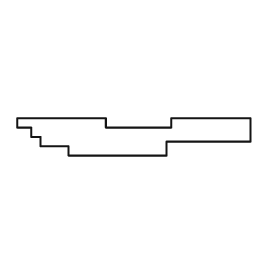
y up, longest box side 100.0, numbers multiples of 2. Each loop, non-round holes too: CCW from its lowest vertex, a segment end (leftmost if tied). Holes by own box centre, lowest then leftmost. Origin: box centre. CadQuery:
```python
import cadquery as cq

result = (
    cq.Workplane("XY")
    .moveTo(-28.0, -8.0)
    .lineTo(14.0, -8.0)
    .lineTo(14.0, -2.0)
    .lineTo(50.0, -2.0)
    .lineTo(50.0, 8.0)
    .lineTo(16.0, 8.0)
    .lineTo(16.0, 4.0)
    .lineTo(-12.0, 4.0)
    .lineTo(-12.0, 8.0)
    .lineTo(-50.0, 8.0)
    .lineTo(-50.0, 4.0)
    .lineTo(-44.0, 4.0)
    .lineTo(-44.0, 0.0)
    .lineTo(-40.0, 0.0)
    .lineTo(-40.0, -4.0)
    .lineTo(-28.0, -4.0)
    .close()
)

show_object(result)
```